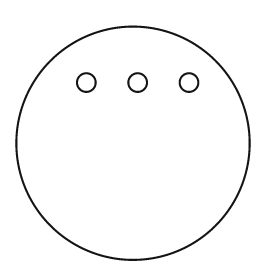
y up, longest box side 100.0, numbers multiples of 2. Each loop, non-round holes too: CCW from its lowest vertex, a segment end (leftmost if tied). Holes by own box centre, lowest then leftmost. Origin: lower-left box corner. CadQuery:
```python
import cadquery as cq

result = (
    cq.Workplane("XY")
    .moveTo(50.0, 50.0)
    .circle(50.0)
    .moveTo(30.0, 76.0)
    .circle(4.0)
    .moveTo(52.0, 76.0)
    .circle(4.0)
    .moveTo(74.0, 76.0)
    .circle(4.0)
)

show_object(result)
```